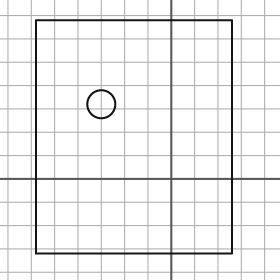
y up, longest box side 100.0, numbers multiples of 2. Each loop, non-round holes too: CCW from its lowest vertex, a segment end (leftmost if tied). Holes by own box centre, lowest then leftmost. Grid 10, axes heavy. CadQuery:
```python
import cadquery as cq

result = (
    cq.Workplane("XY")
    .moveTo(-58.0, -32.0)
    .lineTo(26.0, -32.0)
    .lineTo(26.0, 68.0)
    .lineTo(-58.0, 68.0)
    .close()
    .moveTo(-30.0, 32.0)
    .circle(6.0)
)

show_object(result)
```